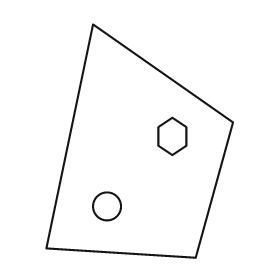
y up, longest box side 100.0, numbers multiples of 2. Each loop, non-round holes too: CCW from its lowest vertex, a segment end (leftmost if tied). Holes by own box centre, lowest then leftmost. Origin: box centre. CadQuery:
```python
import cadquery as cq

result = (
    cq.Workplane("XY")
    .moveTo(24.0, -50.0)
    .lineTo(40.0, 8.0)
    .lineTo(-20.0, 50.0)
    .lineTo(-40.0, -46.0)
    .close()
    .moveTo(-14.0, -28.0)
    .circle(6.0)
    .moveTo(14.0, -6.0)
    .lineTo(20.0, -2.0)
    .lineTo(20.0, 6.0)
    .lineTo(14.0, 10.0)
    .lineTo(8.0, 6.0)
    .lineTo(8.0, -2.0)
    .close()
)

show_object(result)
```